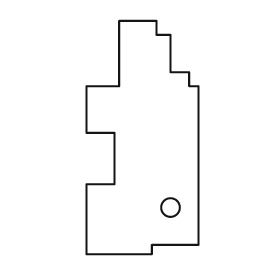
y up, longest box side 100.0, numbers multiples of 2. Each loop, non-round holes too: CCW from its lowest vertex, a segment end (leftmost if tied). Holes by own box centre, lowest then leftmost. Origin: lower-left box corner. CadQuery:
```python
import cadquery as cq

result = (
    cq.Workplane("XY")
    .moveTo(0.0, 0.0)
    .lineTo(28.0, 0.0)
    .lineTo(28.0, 4.0)
    .lineTo(48.0, 4.0)
    .lineTo(48.0, 72.0)
    .lineTo(44.0, 72.0)
    .lineTo(44.0, 78.0)
    .lineTo(36.0, 78.0)
    .lineTo(36.0, 94.0)
    .lineTo(30.0, 94.0)
    .lineTo(30.0, 100.0)
    .lineTo(14.0, 100.0)
    .lineTo(14.0, 72.0)
    .lineTo(0.0, 72.0)
    .lineTo(0.0, 52.0)
    .lineTo(12.0, 52.0)
    .lineTo(12.0, 30.0)
    .lineTo(0.0, 30.0)
    .close()
    .moveTo(36.0, 20.0)
    .circle(4.0)
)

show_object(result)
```